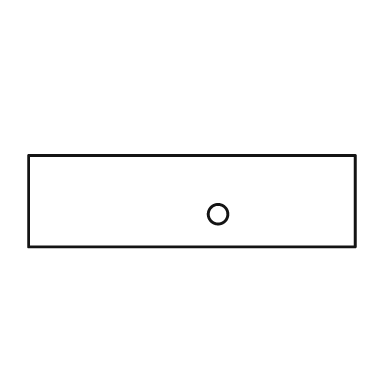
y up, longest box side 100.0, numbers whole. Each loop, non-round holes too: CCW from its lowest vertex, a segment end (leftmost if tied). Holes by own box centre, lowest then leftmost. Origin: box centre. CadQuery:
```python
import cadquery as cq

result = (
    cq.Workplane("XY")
    .moveTo(-50.0, -14.0)
    .lineTo(50.0, -14.0)
    .lineTo(50.0, 14.0)
    .lineTo(-50.0, 14.0)
    .close()
    .moveTo(8.0, -4.0)
    .circle(3.0)
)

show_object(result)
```